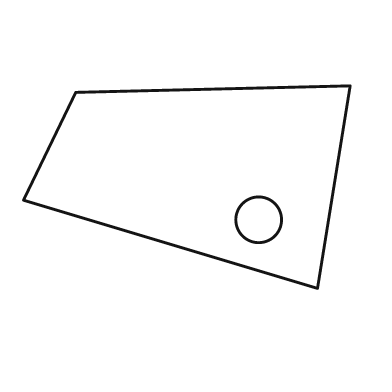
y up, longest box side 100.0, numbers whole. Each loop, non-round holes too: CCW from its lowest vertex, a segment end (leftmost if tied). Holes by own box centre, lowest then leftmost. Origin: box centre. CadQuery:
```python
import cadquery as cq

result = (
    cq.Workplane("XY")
    .moveTo(40.0, -31.0)
    .lineTo(50.0, 31.0)
    .lineTo(-34.0, 29.0)
    .lineTo(-50.0, -4.0)
    .close()
    .moveTo(22.0, -10.0)
    .circle(7.0)
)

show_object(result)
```